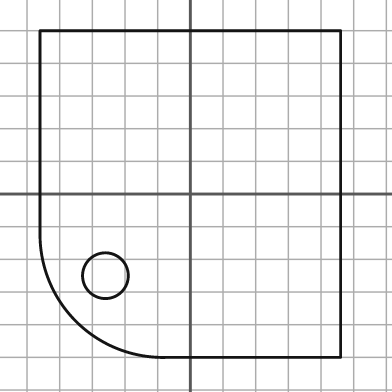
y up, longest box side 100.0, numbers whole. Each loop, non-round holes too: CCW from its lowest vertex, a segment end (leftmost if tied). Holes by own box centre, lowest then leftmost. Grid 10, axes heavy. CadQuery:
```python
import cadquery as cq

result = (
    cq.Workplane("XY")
    .moveTo(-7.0, -50.0)
    .lineTo(46.0, -50.0)
    .lineTo(46.0, 50.0)
    .lineTo(-46.0, 50.0)
    .lineTo(-46.0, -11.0)
    .threePointArc((-35.0, -39.0), (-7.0, -50.0))
    .close()
    .moveTo(-26.0, -25.0)
    .circle(7.0)
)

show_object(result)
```